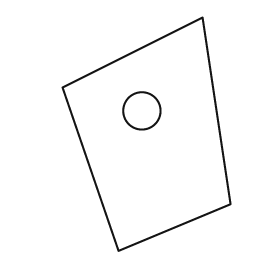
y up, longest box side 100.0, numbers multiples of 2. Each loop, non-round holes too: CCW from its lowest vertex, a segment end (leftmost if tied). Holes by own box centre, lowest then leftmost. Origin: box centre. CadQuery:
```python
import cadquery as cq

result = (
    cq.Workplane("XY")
    .moveTo(-12.0, -50.0)
    .lineTo(36.0, -30.0)
    .lineTo(24.0, 50.0)
    .lineTo(-36.0, 20.0)
    .close()
    .moveTo(-2.0, 10.0)
    .circle(8.0)
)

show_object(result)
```